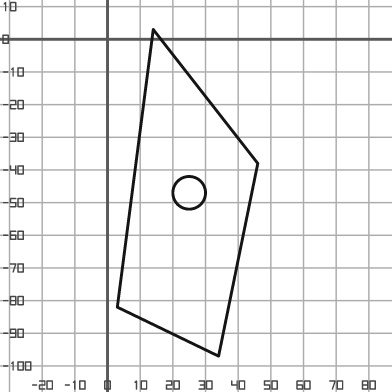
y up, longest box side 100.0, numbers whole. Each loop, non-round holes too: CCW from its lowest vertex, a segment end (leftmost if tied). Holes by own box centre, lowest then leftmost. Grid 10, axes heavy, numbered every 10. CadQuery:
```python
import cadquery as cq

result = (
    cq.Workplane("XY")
    .moveTo(34.0, -97.0)
    .lineTo(46.0, -38.0)
    .lineTo(14.0, 3.0)
    .lineTo(3.0, -82.0)
    .close()
    .moveTo(25.0, -47.0)
    .circle(5.0)
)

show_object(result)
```